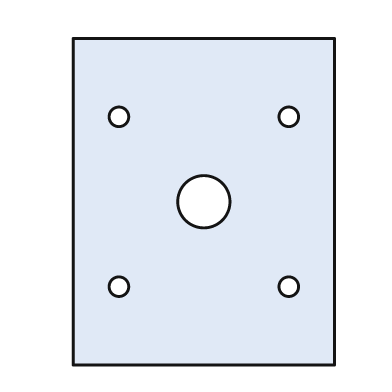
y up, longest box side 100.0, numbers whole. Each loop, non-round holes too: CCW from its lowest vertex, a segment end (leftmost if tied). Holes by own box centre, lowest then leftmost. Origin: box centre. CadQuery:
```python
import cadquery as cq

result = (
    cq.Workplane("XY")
    .moveTo(-40.0, -50.0)
    .lineTo(40.0, -50.0)
    .lineTo(40.0, 50.0)
    .lineTo(-40.0, 50.0)
    .close()
    .moveTo(-26.0, -26.0)
    .circle(3.0)
    .moveTo(26.0, -26.0)
    .circle(3.0)
    .moveTo(0.0, 0.0)
    .circle(8.0)
    .moveTo(-26.0, 26.0)
    .circle(3.0)
    .moveTo(26.0, 26.0)
    .circle(3.0)
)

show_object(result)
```